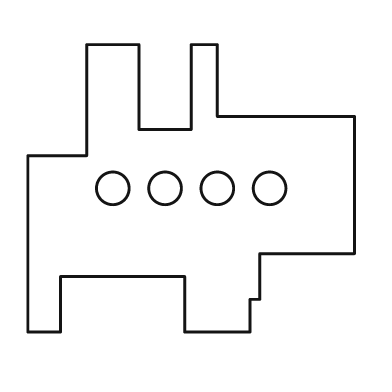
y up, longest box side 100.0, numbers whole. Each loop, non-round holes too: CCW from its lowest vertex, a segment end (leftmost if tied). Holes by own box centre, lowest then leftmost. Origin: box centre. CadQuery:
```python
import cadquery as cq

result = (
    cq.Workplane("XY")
    .moveTo(-50.0, -44.0)
    .lineTo(-40.0, -44.0)
    .lineTo(-40.0, -27.0)
    .lineTo(-2.0, -27.0)
    .lineTo(-2.0, -44.0)
    .lineTo(18.0, -44.0)
    .lineTo(18.0, -34.0)
    .lineTo(21.0, -34.0)
    .lineTo(21.0, -20.0)
    .lineTo(50.0, -20.0)
    .lineTo(50.0, 22.0)
    .lineTo(8.0, 22.0)
    .lineTo(8.0, 44.0)
    .lineTo(0.0, 44.0)
    .lineTo(0.0, 18.0)
    .lineTo(-16.0, 18.0)
    .lineTo(-16.0, 44.0)
    .lineTo(-32.0, 44.0)
    .lineTo(-32.0, 10.0)
    .lineTo(-50.0, 10.0)
    .close()
    .moveTo(-24.0, 0.0)
    .circle(5.0)
    .moveTo(-8.0, 0.0)
    .circle(5.0)
    .moveTo(8.0, 0.0)
    .circle(5.0)
    .moveTo(24.0, 0.0)
    .circle(5.0)
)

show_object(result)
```